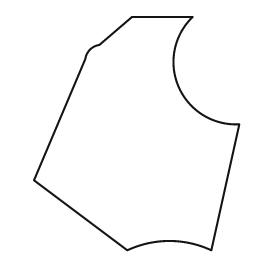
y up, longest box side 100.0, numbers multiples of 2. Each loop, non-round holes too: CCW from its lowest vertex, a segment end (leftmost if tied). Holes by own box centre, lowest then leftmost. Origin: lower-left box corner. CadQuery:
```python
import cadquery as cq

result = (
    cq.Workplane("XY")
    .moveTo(40.0, 0.0)
    .threePointArc((58.0, 4.0), (76.0, 0.0))
    .lineTo(88.0, 54.0)
    .threePointArc((62.0, 70.0), (68.0, 100.0))
    .lineTo(42.0, 100.0)
    .lineTo(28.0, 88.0)
    .threePointArc((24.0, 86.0), (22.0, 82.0))
    .lineTo(0.0, 30.0)
    .close()
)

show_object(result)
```